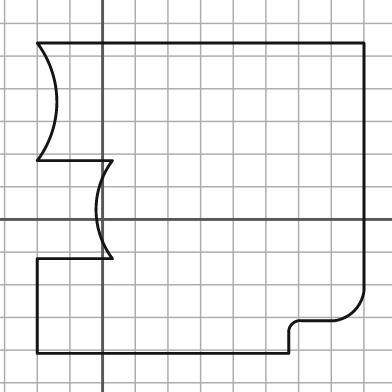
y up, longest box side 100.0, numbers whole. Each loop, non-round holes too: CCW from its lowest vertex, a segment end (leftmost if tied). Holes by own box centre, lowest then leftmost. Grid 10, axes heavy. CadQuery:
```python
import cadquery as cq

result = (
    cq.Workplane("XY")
    .moveTo(-20.0, -41.0)
    .lineTo(57.0, -41.0)
    .lineTo(57.0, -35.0)
    .threePointArc((58.0, -32.0), (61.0, -31.0))
    .lineTo(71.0, -31.0)
    .threePointArc((77.0, -28.0), (80.0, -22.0))
    .lineTo(80.0, 54.0)
    .lineTo(-20.0, 54.0)
    .threePointArc((-14.0, 36.0), (-20.0, 18.0))
    .lineTo(3.0, 18.0)
    .threePointArc((-2.0, 3.0), (3.0, -12.0))
    .lineTo(-20.0, -12.0)
    .close()
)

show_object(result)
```